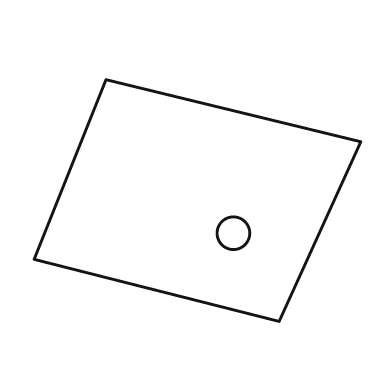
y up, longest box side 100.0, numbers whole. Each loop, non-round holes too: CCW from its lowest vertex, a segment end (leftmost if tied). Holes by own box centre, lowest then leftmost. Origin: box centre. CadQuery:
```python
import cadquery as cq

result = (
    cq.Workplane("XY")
    .moveTo(25.0, -37.0)
    .lineTo(50.0, 18.0)
    .lineTo(-28.0, 37.0)
    .lineTo(-50.0, -18.0)
    .close()
    .moveTo(11.0, -10.0)
    .circle(5.0)
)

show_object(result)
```